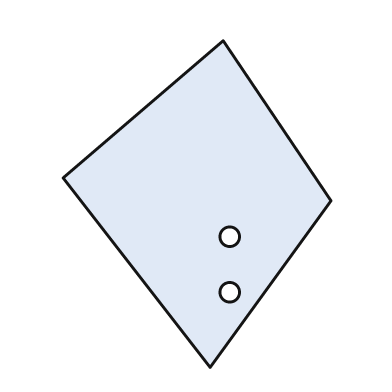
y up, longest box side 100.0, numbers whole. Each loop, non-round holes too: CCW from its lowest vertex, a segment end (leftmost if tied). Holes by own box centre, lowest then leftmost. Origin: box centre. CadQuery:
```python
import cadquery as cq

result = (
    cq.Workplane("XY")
    .moveTo(4.0, -50.0)
    .lineTo(41.0, 1.0)
    .lineTo(8.0, 50.0)
    .lineTo(-41.0, 8.0)
    .close()
    .moveTo(10.0, -27.0)
    .circle(3.0)
    .moveTo(10.0, -10.0)
    .circle(3.0)
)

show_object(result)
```